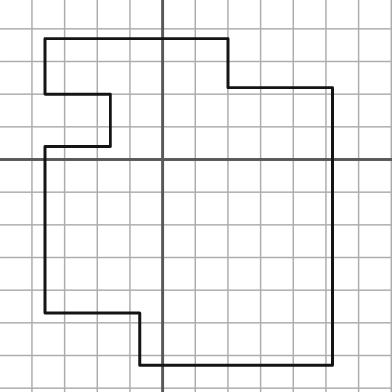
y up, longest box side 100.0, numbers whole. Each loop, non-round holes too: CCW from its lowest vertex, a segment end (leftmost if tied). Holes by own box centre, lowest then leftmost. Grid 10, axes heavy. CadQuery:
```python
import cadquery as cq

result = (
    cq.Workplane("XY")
    .moveTo(-7.0, -63.0)
    .lineTo(52.0, -63.0)
    .lineTo(52.0, 22.0)
    .lineTo(20.0, 22.0)
    .lineTo(20.0, 37.0)
    .lineTo(-36.0, 37.0)
    .lineTo(-36.0, 20.0)
    .lineTo(-16.0, 20.0)
    .lineTo(-16.0, 4.0)
    .lineTo(-36.0, 4.0)
    .lineTo(-36.0, -47.0)
    .lineTo(-7.0, -47.0)
    .close()
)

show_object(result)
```